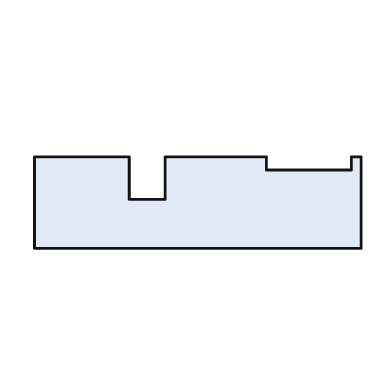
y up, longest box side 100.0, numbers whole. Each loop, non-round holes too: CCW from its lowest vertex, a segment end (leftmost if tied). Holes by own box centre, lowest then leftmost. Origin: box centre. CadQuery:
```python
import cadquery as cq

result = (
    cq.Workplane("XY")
    .moveTo(-50.0, -14.0)
    .lineTo(50.0, -14.0)
    .lineTo(50.0, 14.0)
    .lineTo(47.0, 14.0)
    .lineTo(47.0, 10.0)
    .lineTo(21.0, 10.0)
    .lineTo(21.0, 14.0)
    .lineTo(-10.0, 14.0)
    .lineTo(-10.0, 1.0)
    .lineTo(-21.0, 1.0)
    .lineTo(-21.0, 14.0)
    .lineTo(-50.0, 14.0)
    .close()
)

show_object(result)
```